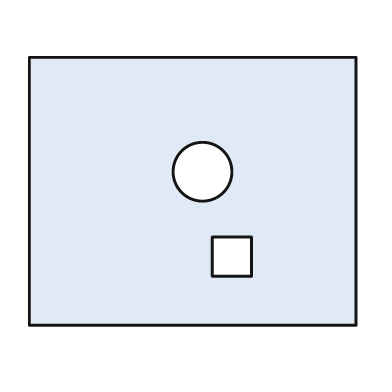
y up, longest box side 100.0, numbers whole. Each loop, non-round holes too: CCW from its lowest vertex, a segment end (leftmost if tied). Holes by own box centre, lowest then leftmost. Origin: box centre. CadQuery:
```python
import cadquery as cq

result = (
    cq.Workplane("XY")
    .moveTo(-50.0, -41.0)
    .lineTo(50.0, -41.0)
    .lineTo(50.0, 41.0)
    .lineTo(-50.0, 41.0)
    .close()
    .moveTo(6.0, -26.0)
    .lineTo(18.0, -26.0)
    .lineTo(18.0, -14.0)
    .lineTo(6.0, -14.0)
    .close()
    .moveTo(3.0, 6.0)
    .circle(9.0)
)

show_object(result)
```